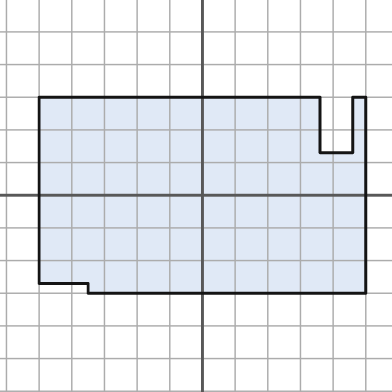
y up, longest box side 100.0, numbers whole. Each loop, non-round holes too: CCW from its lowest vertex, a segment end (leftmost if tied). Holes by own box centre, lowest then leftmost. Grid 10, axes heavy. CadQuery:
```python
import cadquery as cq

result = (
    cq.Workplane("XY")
    .moveTo(-35.0, -30.0)
    .lineTo(50.0, -30.0)
    .lineTo(50.0, 30.0)
    .lineTo(46.0, 30.0)
    .lineTo(46.0, 13.0)
    .lineTo(36.0, 13.0)
    .lineTo(36.0, 30.0)
    .lineTo(-50.0, 30.0)
    .lineTo(-50.0, -27.0)
    .lineTo(-35.0, -27.0)
    .close()
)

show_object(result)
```